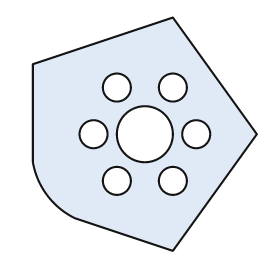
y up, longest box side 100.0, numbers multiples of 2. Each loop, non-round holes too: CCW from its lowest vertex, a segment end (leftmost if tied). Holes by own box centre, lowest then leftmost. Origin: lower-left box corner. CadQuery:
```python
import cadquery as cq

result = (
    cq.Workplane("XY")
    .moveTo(60.0, 0.0)
    .lineTo(96.0, 50.0)
    .lineTo(60.0, 100.0)
    .lineTo(0.0, 80.0)
    .lineTo(0.0, 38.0)
    .threePointArc((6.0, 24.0), (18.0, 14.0))
    .close()
    .moveTo(36.0, 30.0)
    .circle(6.0)
    .moveTo(60.0, 30.0)
    .circle(6.0)
    .moveTo(26.0, 50.0)
    .circle(6.0)
    .moveTo(48.0, 50.0)
    .circle(12.0)
    .moveTo(70.0, 50.0)
    .circle(6.0)
    .moveTo(36.0, 70.0)
    .circle(6.0)
    .moveTo(60.0, 70.0)
    .circle(6.0)
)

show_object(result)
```